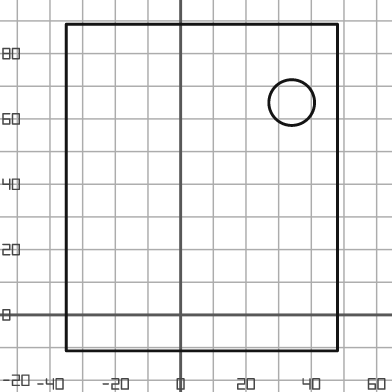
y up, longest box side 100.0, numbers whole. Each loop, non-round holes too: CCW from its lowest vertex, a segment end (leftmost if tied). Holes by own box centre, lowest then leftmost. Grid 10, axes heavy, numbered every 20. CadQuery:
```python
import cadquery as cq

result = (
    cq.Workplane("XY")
    .moveTo(-35.0, -11.0)
    .lineTo(48.0, -11.0)
    .lineTo(48.0, 89.0)
    .lineTo(-35.0, 89.0)
    .close()
    .moveTo(34.0, 65.0)
    .circle(7.0)
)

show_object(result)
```